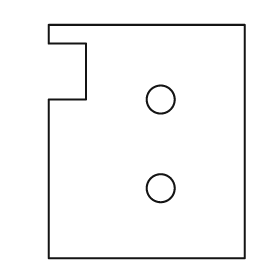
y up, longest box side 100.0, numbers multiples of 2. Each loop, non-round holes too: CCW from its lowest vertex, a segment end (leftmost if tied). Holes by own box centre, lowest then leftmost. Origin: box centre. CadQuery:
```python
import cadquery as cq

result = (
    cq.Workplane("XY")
    .moveTo(-42.0, -50.0)
    .lineTo(42.0, -50.0)
    .lineTo(42.0, 50.0)
    .lineTo(-42.0, 50.0)
    .lineTo(-42.0, 42.0)
    .lineTo(-26.0, 42.0)
    .lineTo(-26.0, 18.0)
    .lineTo(-42.0, 18.0)
    .close()
    .moveTo(6.0, -20.0)
    .circle(6.0)
    .moveTo(6.0, 18.0)
    .circle(6.0)
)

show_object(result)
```